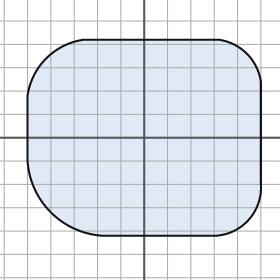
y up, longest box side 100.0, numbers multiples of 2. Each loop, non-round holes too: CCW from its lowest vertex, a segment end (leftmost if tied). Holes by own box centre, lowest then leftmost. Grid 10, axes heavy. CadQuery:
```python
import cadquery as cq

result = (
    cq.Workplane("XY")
    .moveTo(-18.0, -42.0)
    .lineTo(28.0, -42.0)
    .threePointArc((44.0, -36.0), (50.0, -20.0))
    .lineTo(50.0, 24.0)
    .threePointArc((44.0, 36.0), (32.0, 42.0))
    .lineTo(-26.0, 42.0)
    .threePointArc((-42.0, 34.0), (-50.0, 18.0))
    .lineTo(-50.0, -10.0)
    .threePointArc((-40.0, -32.0), (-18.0, -42.0))
    .close()
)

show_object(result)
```